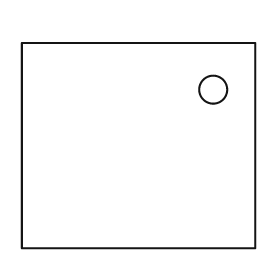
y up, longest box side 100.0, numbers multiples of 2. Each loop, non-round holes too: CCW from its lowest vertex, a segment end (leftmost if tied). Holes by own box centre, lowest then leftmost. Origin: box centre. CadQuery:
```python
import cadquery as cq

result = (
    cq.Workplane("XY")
    .moveTo(-50.0, -44.0)
    .lineTo(50.0, -44.0)
    .lineTo(50.0, 44.0)
    .lineTo(-50.0, 44.0)
    .close()
    .moveTo(32.0, 24.0)
    .circle(6.0)
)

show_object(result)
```